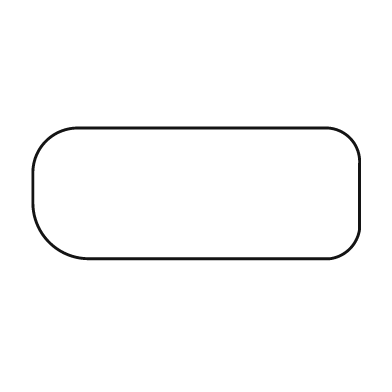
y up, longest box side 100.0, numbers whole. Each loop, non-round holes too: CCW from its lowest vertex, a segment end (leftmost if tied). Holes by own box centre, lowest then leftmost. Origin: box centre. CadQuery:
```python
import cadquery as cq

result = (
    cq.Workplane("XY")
    .moveTo(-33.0, -20.0)
    .lineTo(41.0, -20.0)
    .threePointArc((47.0, -17.0), (50.0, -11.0))
    .lineTo(50.0, 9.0)
    .threePointArc((47.0, 17.0), (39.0, 20.0))
    .lineTo(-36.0, 20.0)
    .threePointArc((-46.0, 16.0), (-50.0, 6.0))
    .lineTo(-50.0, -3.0)
    .threePointArc((-45.0, -15.0), (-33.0, -20.0))
    .close()
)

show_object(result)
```